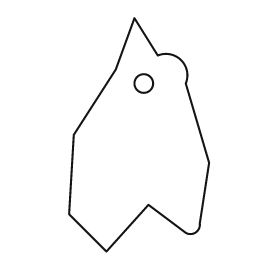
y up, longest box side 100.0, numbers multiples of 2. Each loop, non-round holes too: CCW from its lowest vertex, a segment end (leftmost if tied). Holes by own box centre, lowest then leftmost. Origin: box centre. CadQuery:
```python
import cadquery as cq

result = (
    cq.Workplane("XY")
    .moveTo(-14.0, -50.0)
    .lineTo(4.0, -30.0)
    .lineTo(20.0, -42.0)
    .threePointArc((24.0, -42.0), (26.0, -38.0))
    .lineTo(30.0, -12.0)
    .lineTo(20.0, 22.0)
    .threePointArc((18.0, 32.0), (8.0, 34.0))
    .lineTo(-2.0, 50.0)
    .lineTo(-10.0, 28.0)
    .lineTo(-28.0, 0.0)
    .lineTo(-30.0, -34.0)
    .close()
    .moveTo(2.0, 22.0)
    .circle(4.0)
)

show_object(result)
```